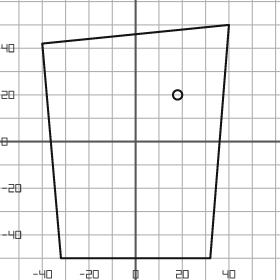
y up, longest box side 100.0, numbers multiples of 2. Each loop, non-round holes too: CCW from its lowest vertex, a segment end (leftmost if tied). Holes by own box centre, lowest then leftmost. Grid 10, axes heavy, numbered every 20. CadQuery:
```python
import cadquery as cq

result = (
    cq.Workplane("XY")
    .moveTo(-32.0, -50.0)
    .lineTo(32.0, -50.0)
    .lineTo(40.0, 50.0)
    .lineTo(-40.0, 42.0)
    .close()
    .moveTo(18.0, 20.0)
    .circle(2.0)
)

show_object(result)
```